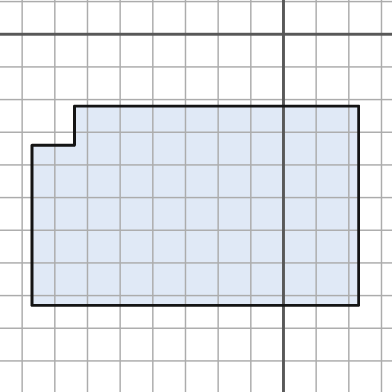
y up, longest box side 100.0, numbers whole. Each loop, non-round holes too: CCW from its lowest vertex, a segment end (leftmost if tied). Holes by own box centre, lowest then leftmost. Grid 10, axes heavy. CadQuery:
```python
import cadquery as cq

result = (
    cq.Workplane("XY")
    .moveTo(-77.0, -83.0)
    .lineTo(23.0, -83.0)
    .lineTo(23.0, -22.0)
    .lineTo(-64.0, -22.0)
    .lineTo(-64.0, -34.0)
    .lineTo(-77.0, -34.0)
    .close()
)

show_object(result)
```